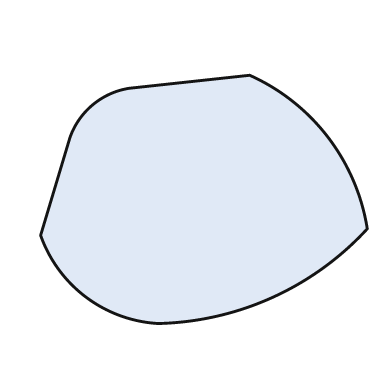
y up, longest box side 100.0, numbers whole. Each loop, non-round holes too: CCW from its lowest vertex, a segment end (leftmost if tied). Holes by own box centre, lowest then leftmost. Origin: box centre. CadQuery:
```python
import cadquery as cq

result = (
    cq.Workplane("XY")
    .moveTo(-14.0, -38.0)
    .threePointArc((21.0, -30.0), (50.0, -9.0))
    .threePointArc((38.0, 19.0), (14.0, 38.0))
    .lineTo(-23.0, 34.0)
    .threePointArc((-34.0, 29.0), (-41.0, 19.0))
    .lineTo(-50.0, -11.0)
    .threePointArc((-36.0, -30.0), (-14.0, -38.0))
    .close()
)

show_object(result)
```